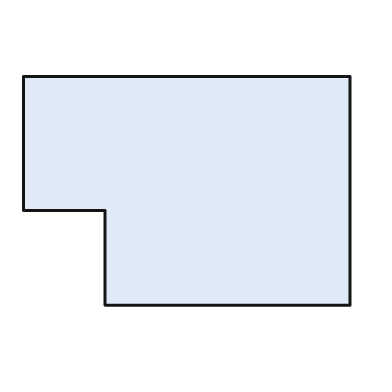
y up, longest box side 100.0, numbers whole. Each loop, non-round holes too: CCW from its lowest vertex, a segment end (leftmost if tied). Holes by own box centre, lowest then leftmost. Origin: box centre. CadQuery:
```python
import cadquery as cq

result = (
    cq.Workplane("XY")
    .moveTo(-25.0, -35.0)
    .lineTo(50.0, -35.0)
    .lineTo(50.0, 35.0)
    .lineTo(-50.0, 35.0)
    .lineTo(-50.0, -6.0)
    .lineTo(-25.0, -6.0)
    .close()
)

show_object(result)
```